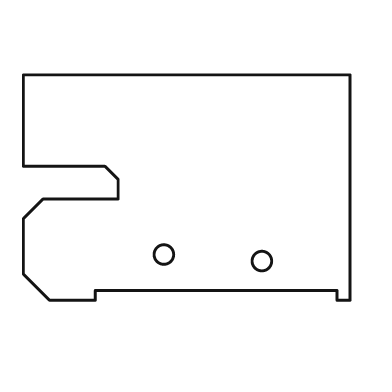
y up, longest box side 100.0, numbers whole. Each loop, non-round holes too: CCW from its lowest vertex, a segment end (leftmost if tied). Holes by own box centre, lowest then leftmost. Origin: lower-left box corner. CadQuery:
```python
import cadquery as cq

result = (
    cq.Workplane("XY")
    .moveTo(8.0, 0.0)
    .lineTo(22.0, 0.0)
    .lineTo(22.0, 3.0)
    .lineTo(96.0, 3.0)
    .lineTo(96.0, 0.0)
    .lineTo(100.0, 0.0)
    .lineTo(100.0, 69.0)
    .lineTo(0.0, 69.0)
    .lineTo(0.0, 41.0)
    .lineTo(25.0, 41.0)
    .lineTo(29.0, 37.0)
    .lineTo(29.0, 31.0)
    .lineTo(6.0, 31.0)
    .lineTo(0.0, 25.0)
    .lineTo(0.0, 8.0)
    .close()
    .moveTo(73.0, 12.0)
    .circle(3.0)
    .moveTo(43.0, 14.0)
    .circle(3.0)
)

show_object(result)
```